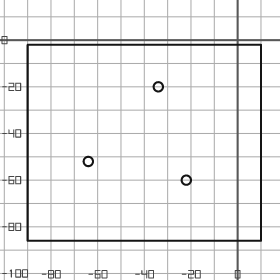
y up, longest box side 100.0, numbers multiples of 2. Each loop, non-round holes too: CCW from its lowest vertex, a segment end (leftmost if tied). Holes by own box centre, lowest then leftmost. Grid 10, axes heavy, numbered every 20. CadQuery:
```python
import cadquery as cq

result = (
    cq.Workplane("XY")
    .moveTo(-90.0, -86.0)
    .lineTo(10.0, -86.0)
    .lineTo(10.0, -2.0)
    .lineTo(-90.0, -2.0)
    .close()
    .moveTo(-22.0, -60.0)
    .circle(2.0)
    .moveTo(-64.0, -52.0)
    .circle(2.0)
    .moveTo(-34.0, -20.0)
    .circle(2.0)
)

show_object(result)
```